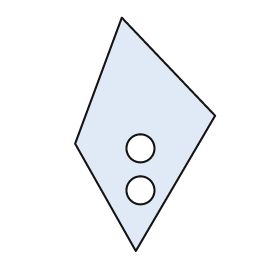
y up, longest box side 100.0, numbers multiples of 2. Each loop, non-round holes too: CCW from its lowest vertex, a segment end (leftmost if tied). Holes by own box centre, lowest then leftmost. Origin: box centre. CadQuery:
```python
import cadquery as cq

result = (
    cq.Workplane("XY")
    .moveTo(-4.0, -50.0)
    .lineTo(30.0, 8.0)
    .lineTo(-10.0, 50.0)
    .lineTo(-30.0, -4.0)
    .close()
    .moveTo(-2.0, -24.0)
    .circle(6.0)
    .moveTo(-2.0, -6.0)
    .circle(6.0)
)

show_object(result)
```